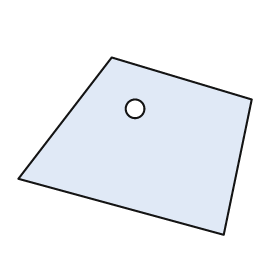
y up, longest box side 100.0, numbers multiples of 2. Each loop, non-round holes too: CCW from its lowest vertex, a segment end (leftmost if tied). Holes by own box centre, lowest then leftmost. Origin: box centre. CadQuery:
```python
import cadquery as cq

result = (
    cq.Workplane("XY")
    .moveTo(38.0, -38.0)
    .lineTo(50.0, 20.0)
    .lineTo(-10.0, 38.0)
    .lineTo(-50.0, -14.0)
    .close()
    .moveTo(0.0, 16.0)
    .circle(4.0)
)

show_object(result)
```